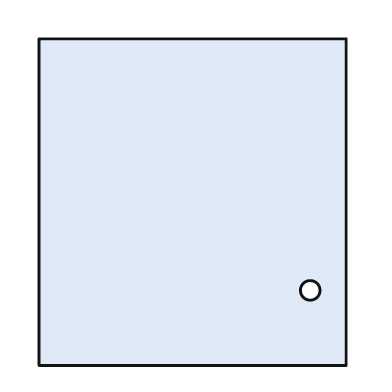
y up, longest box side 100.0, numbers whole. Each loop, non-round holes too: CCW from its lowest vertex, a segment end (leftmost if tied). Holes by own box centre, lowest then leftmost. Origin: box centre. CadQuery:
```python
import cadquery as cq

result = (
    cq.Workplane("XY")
    .moveTo(-47.0, -50.0)
    .lineTo(47.0, -50.0)
    .lineTo(47.0, 50.0)
    .lineTo(-47.0, 50.0)
    .close()
    .moveTo(36.0, -27.0)
    .circle(3.0)
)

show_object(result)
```